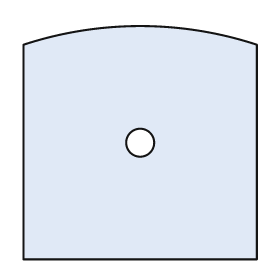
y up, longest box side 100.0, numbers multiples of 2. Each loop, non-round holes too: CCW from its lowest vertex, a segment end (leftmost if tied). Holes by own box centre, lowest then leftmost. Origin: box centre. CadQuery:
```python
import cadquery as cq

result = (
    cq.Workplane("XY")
    .moveTo(-50.0, -50.0)
    .lineTo(50.0, -50.0)
    .lineTo(50.0, 42.0)
    .threePointArc((0.0, 50.0), (-50.0, 42.0))
    .close()
    .moveTo(0.0, 0.0)
    .circle(6.0)
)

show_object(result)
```